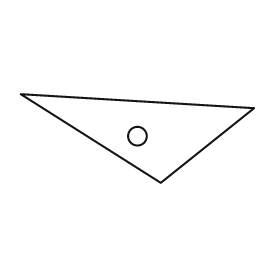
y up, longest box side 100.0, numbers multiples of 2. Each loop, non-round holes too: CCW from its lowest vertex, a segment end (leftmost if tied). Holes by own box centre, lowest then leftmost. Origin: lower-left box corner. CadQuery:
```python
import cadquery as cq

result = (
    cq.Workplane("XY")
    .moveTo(60.0, 0.0)
    .lineTo(100.0, 32.0)
    .lineTo(0.0, 38.0)
    .close()
    .moveTo(50.0, 20.0)
    .circle(4.0)
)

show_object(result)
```